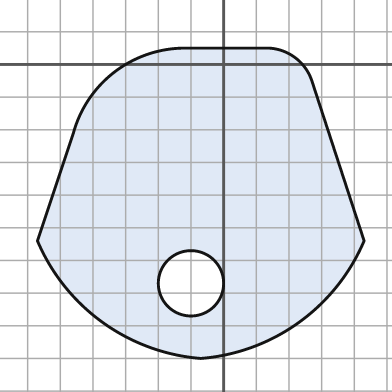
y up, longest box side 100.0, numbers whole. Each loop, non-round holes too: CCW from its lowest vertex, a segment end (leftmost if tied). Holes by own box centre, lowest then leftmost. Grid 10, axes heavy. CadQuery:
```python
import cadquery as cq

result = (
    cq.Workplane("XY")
    .moveTo(-7.0, -90.0)
    .threePointArc((23.0, -79.0), (43.0, -54.0))
    .lineTo(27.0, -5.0)
    .threePointArc((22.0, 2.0), (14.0, 5.0))
    .lineTo(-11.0, 5.0)
    .threePointArc((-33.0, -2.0), (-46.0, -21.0))
    .lineTo(-57.0, -54.0)
    .threePointArc((-37.0, -79.0), (-7.0, -90.0))
    .close()
    .moveTo(-10.0, -67.0)
    .circle(10.0)
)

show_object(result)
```